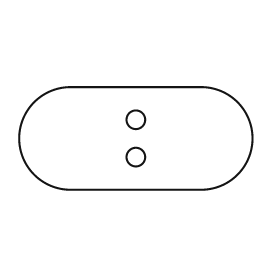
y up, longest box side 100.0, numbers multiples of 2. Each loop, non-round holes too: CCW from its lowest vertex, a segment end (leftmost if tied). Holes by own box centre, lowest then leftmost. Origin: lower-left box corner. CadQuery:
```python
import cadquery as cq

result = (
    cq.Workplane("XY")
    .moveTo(22.0, 0.0)
    .lineTo(78.0, 0.0)
    .threePointArc((100.0, 22.0), (78.0, 44.0))
    .lineTo(22.0, 44.0)
    .threePointArc((0.0, 22.0), (22.0, 0.0))
    .close()
    .moveTo(50.0, 14.0)
    .circle(4.0)
    .moveTo(50.0, 30.0)
    .circle(4.0)
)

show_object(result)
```